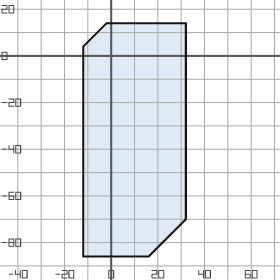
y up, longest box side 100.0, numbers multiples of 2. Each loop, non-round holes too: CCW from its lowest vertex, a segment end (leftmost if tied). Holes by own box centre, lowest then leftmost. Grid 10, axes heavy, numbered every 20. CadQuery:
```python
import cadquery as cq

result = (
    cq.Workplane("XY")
    .moveTo(-12.0, -86.0)
    .lineTo(16.0, -86.0)
    .lineTo(32.0, -70.0)
    .lineTo(32.0, 14.0)
    .lineTo(-2.0, 14.0)
    .lineTo(-12.0, 4.0)
    .close()
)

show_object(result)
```